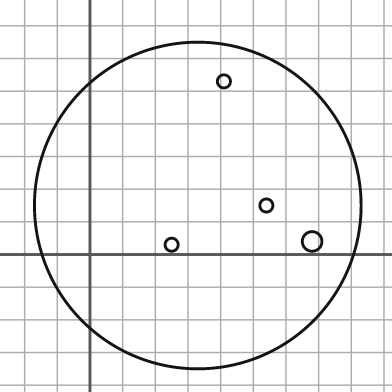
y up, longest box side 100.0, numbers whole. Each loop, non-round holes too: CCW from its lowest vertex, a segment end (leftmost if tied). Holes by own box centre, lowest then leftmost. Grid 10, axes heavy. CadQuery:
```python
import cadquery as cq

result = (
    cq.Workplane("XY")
    .moveTo(33.0, 15.0)
    .circle(50.0)
    .moveTo(25.0, 3.0)
    .circle(2.0)
    .moveTo(68.0, 4.0)
    .circle(3.0)
    .moveTo(54.0, 15.0)
    .circle(2.0)
    .moveTo(41.0, 53.0)
    .circle(2.0)
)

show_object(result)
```